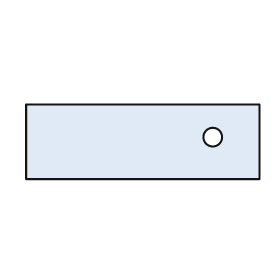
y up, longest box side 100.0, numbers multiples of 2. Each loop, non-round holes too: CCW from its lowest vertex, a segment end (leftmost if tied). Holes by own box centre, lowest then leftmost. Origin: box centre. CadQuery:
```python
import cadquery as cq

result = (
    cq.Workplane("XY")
    .moveTo(-50.0, -16.0)
    .lineTo(50.0, -16.0)
    .lineTo(50.0, 16.0)
    .lineTo(-50.0, 16.0)
    .close()
    .moveTo(30.0, 2.0)
    .circle(4.0)
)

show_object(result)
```